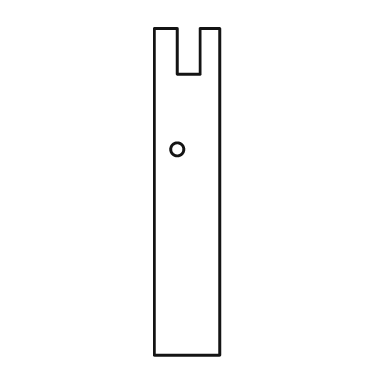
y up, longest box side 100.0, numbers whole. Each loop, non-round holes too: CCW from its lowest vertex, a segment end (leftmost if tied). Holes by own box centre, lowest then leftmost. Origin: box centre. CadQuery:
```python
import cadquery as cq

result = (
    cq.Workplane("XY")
    .moveTo(-10.0, -50.0)
    .lineTo(10.0, -50.0)
    .lineTo(10.0, 50.0)
    .lineTo(4.0, 50.0)
    .lineTo(4.0, 36.0)
    .lineTo(-3.0, 36.0)
    .lineTo(-3.0, 50.0)
    .lineTo(-10.0, 50.0)
    .close()
    .moveTo(-3.0, 13.0)
    .circle(2.0)
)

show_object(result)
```